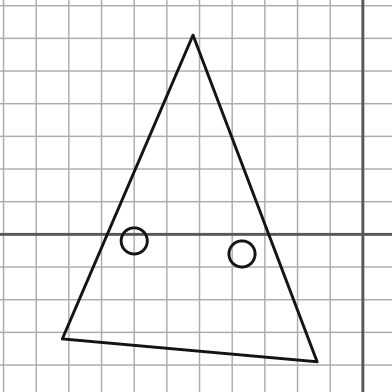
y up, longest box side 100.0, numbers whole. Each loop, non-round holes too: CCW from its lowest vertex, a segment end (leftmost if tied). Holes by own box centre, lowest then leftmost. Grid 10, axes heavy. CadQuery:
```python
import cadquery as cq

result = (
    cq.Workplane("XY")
    .moveTo(-14.0, -39.0)
    .lineTo(-52.0, 61.0)
    .lineTo(-92.0, -32.0)
    .close()
    .moveTo(-37.0, -6.0)
    .circle(4.0)
    .moveTo(-70.0, -2.0)
    .circle(4.0)
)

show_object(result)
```